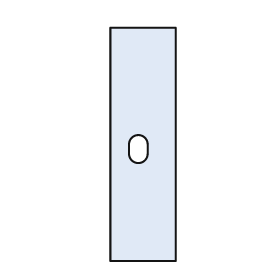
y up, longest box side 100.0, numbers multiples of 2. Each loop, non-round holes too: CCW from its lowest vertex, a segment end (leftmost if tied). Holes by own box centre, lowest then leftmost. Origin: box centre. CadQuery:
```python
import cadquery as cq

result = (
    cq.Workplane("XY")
    .moveTo(-14.0, -50.0)
    .lineTo(14.0, -50.0)
    .lineTo(14.0, 50.0)
    .lineTo(-14.0, 50.0)
    .close()
    .moveTo(-6.0, -4.0)
    .threePointArc((-2.0, -8.0), (2.0, -4.0))
    .lineTo(2.0, 0.0)
    .threePointArc((-2.0, 4.0), (-6.0, 0.0))
    .close()
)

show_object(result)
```